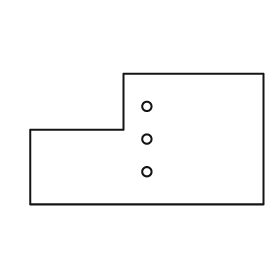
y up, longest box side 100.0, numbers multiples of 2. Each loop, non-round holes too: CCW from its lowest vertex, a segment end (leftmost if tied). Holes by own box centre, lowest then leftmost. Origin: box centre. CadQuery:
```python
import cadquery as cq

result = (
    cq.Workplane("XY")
    .moveTo(-50.0, -28.0)
    .lineTo(50.0, -28.0)
    .lineTo(50.0, 28.0)
    .lineTo(-10.0, 28.0)
    .lineTo(-10.0, 4.0)
    .lineTo(-50.0, 4.0)
    .close()
    .moveTo(0.0, -14.0)
    .circle(2.0)
    .moveTo(0.0, 0.0)
    .circle(2.0)
    .moveTo(0.0, 14.0)
    .circle(2.0)
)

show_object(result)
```